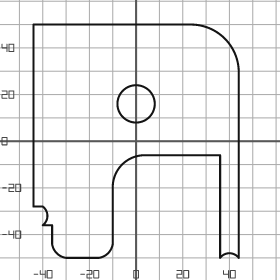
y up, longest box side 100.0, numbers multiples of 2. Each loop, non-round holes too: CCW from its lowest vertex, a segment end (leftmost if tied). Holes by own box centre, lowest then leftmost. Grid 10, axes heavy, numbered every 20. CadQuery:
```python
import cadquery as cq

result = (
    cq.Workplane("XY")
    .moveTo(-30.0, -50.0)
    .lineTo(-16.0, -50.0)
    .threePointArc((-12.0, -48.0), (-10.0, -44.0))
    .lineTo(-10.0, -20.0)
    .threePointArc((-6.0, -10.0), (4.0, -6.0))
    .lineTo(36.0, -6.0)
    .lineTo(36.0, -50.0)
    .threePointArc((40.0, -48.0), (44.0, -50.0))
    .lineTo(44.0, 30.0)
    .threePointArc((38.0, 44.0), (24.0, 50.0))
    .lineTo(-44.0, 50.0)
    .lineTo(-44.0, -28.0)
    .lineTo(-40.0, -28.0)
    .threePointArc((-38.0, -32.0), (-40.0, -36.0))
    .lineTo(-36.0, -36.0)
    .lineTo(-36.0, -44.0)
    .threePointArc((-34.0, -48.0), (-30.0, -50.0))
    .close()
    .moveTo(0.0, 16.0)
    .circle(8.0)
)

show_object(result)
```